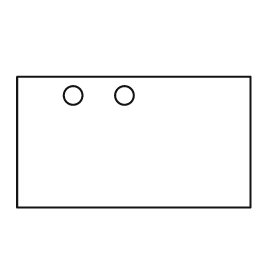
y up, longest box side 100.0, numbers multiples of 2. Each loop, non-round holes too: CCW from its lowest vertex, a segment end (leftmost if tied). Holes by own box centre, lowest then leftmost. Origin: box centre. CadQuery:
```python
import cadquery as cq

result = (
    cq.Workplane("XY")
    .moveTo(-50.0, -28.0)
    .lineTo(50.0, -28.0)
    .lineTo(50.0, 28.0)
    .lineTo(-50.0, 28.0)
    .close()
    .moveTo(-26.0, 20.0)
    .circle(4.0)
    .moveTo(-4.0, 20.0)
    .circle(4.0)
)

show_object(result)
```